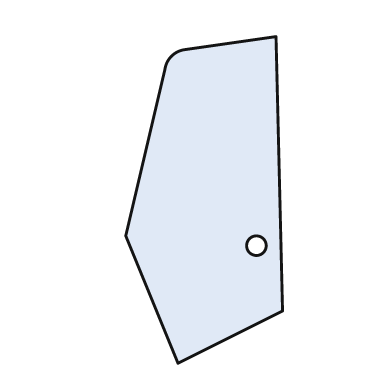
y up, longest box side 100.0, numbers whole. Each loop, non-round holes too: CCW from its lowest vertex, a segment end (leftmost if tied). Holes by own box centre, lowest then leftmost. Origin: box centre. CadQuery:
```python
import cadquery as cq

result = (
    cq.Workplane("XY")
    .moveTo(-8.0, -50.0)
    .lineTo(24.0, -34.0)
    .lineTo(22.0, 50.0)
    .lineTo(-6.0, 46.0)
    .threePointArc((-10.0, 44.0), (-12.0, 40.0))
    .lineTo(-24.0, -11.0)
    .close()
    .moveTo(16.0, -14.0)
    .circle(3.0)
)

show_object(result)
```